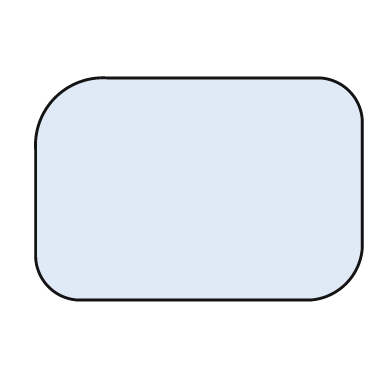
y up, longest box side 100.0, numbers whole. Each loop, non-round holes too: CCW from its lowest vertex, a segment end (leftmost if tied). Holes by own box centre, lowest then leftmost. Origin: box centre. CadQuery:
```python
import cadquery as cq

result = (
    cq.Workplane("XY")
    .moveTo(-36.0, -34.0)
    .lineTo(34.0, -34.0)
    .threePointArc((45.0, -29.0), (50.0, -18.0))
    .lineTo(50.0, 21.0)
    .threePointArc((46.0, 30.0), (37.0, 34.0))
    .lineTo(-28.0, 34.0)
    .threePointArc((-44.0, 28.0), (-50.0, 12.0))
    .lineTo(-50.0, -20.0)
    .threePointArc((-46.0, -30.0), (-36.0, -34.0))
    .close()
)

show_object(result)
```